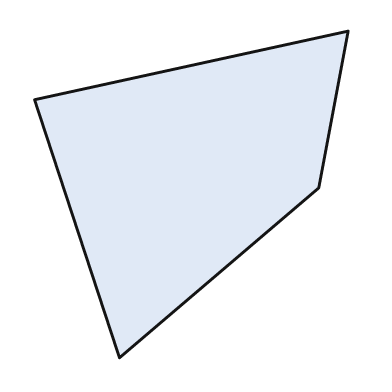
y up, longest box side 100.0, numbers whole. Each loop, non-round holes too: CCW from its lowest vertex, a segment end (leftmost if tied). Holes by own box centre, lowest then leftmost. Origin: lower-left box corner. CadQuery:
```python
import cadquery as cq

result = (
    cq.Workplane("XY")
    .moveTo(26.0, 0.0)
    .lineTo(87.0, 52.0)
    .lineTo(96.0, 100.0)
    .lineTo(0.0, 79.0)
    .close()
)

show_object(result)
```